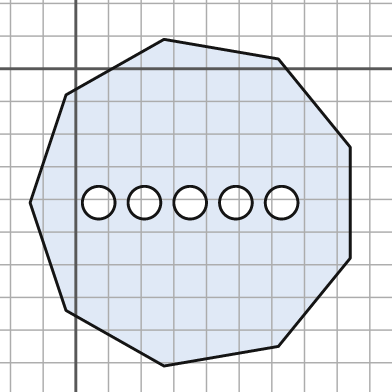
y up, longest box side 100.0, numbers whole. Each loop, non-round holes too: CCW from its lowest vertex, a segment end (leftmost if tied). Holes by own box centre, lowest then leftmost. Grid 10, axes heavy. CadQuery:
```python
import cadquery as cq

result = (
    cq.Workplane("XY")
    .moveTo(27.0, -91.0)
    .lineTo(62.0, -85.0)
    .lineTo(84.0, -58.0)
    .lineTo(84.0, -24.0)
    .lineTo(62.0, 3.0)
    .lineTo(27.0, 9.0)
    .lineTo(-3.0, -8.0)
    .lineTo(-14.0, -41.0)
    .lineTo(-3.0, -74.0)
    .close()
    .moveTo(7.0, -41.0)
    .circle(5.0)
    .moveTo(21.0, -41.0)
    .circle(5.0)
    .moveTo(35.0, -41.0)
    .circle(5.0)
    .moveTo(49.0, -41.0)
    .circle(5.0)
    .moveTo(63.0, -41.0)
    .circle(5.0)
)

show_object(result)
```